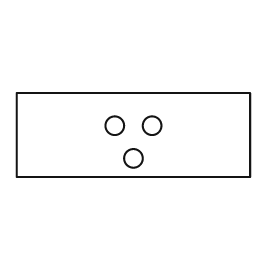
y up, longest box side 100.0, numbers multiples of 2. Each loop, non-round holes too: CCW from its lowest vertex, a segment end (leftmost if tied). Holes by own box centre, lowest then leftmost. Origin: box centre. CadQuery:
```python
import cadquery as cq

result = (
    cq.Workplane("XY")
    .moveTo(-50.0, -18.0)
    .lineTo(50.0, -18.0)
    .lineTo(50.0, 18.0)
    .lineTo(-50.0, 18.0)
    .close()
    .moveTo(0.0, -10.0)
    .circle(4.0)
    .moveTo(-8.0, 4.0)
    .circle(4.0)
    .moveTo(8.0, 4.0)
    .circle(4.0)
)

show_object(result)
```